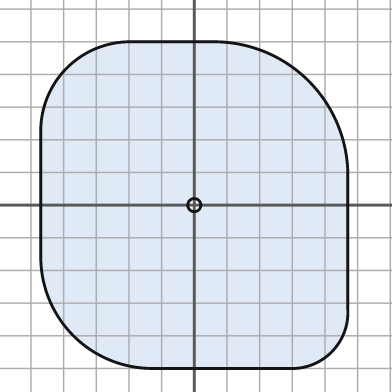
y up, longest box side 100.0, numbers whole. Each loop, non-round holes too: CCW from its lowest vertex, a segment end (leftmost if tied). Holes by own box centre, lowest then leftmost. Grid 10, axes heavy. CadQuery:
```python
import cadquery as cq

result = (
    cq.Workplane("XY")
    .moveTo(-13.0, -50.0)
    .lineTo(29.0, -50.0)
    .threePointArc((42.0, -45.0), (47.0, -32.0))
    .lineTo(47.0, 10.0)
    .threePointArc((35.0, 38.0), (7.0, 50.0))
    .lineTo(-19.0, 50.0)
    .threePointArc((-39.0, 42.0), (-47.0, 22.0))
    .lineTo(-47.0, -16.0)
    .threePointArc((-37.0, -40.0), (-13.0, -50.0))
    .close()
    .moveTo(0.0, 0.0)
    .circle(2.0)
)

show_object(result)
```